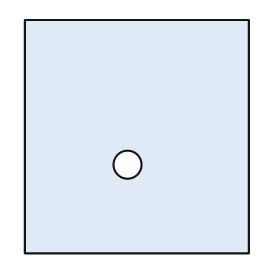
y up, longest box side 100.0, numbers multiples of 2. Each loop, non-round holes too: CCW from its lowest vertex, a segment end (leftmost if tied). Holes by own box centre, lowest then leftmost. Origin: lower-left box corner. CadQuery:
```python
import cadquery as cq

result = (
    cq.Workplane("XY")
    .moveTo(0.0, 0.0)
    .lineTo(96.0, 0.0)
    .lineTo(96.0, 100.0)
    .lineTo(0.0, 100.0)
    .close()
    .moveTo(44.0, 38.0)
    .circle(6.0)
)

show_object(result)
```